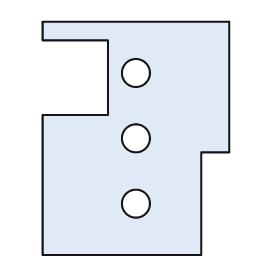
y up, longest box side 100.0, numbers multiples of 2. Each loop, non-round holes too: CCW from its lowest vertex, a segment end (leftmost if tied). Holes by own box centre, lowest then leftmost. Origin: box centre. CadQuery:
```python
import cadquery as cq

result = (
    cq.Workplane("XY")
    .moveTo(-40.0, -50.0)
    .lineTo(28.0, -50.0)
    .lineTo(28.0, -6.0)
    .lineTo(40.0, -6.0)
    .lineTo(40.0, 50.0)
    .lineTo(-40.0, 50.0)
    .lineTo(-40.0, 42.0)
    .lineTo(-12.0, 42.0)
    .lineTo(-12.0, 10.0)
    .lineTo(-40.0, 10.0)
    .close()
    .moveTo(0.0, -28.0)
    .circle(6.0)
    .moveTo(0.0, 0.0)
    .circle(6.0)
    .moveTo(0.0, 28.0)
    .circle(6.0)
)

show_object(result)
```